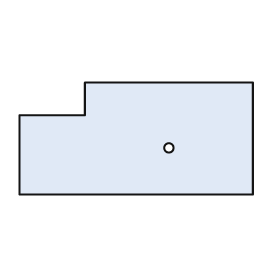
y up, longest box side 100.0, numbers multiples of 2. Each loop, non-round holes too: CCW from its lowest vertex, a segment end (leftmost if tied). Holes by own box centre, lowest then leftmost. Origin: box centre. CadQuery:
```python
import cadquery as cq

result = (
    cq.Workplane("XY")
    .moveTo(-50.0, -24.0)
    .lineTo(50.0, -24.0)
    .lineTo(50.0, 24.0)
    .lineTo(-22.0, 24.0)
    .lineTo(-22.0, 10.0)
    .lineTo(-50.0, 10.0)
    .close()
    .moveTo(14.0, -4.0)
    .circle(2.0)
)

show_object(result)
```